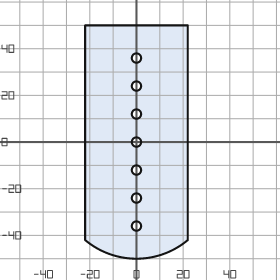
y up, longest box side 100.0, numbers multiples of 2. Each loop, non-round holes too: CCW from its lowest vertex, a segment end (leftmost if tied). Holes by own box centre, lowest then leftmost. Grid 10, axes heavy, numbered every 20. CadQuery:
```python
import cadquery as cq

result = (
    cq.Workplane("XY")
    .moveTo(-22.0, -42.0)
    .threePointArc((0.0, -50.0), (22.0, -42.0))
    .lineTo(22.0, 50.0)
    .lineTo(-22.0, 50.0)
    .close()
    .moveTo(0.0, -36.0)
    .circle(2.0)
    .moveTo(0.0, -24.0)
    .circle(2.0)
    .moveTo(0.0, -12.0)
    .circle(2.0)
    .moveTo(0.0, 0.0)
    .circle(2.0)
    .moveTo(0.0, 12.0)
    .circle(2.0)
    .moveTo(0.0, 24.0)
    .circle(2.0)
    .moveTo(0.0, 36.0)
    .circle(2.0)
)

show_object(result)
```